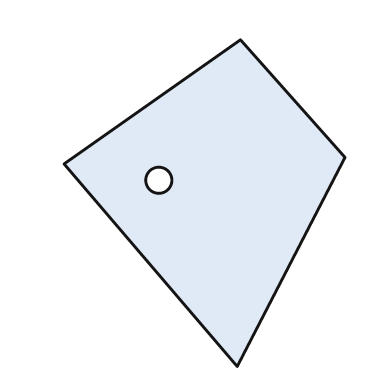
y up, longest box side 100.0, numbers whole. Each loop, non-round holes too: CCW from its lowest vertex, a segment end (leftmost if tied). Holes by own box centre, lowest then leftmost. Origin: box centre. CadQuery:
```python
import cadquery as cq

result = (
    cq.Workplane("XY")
    .moveTo(10.0, -50.0)
    .lineTo(43.0, 14.0)
    .lineTo(11.0, 50.0)
    .lineTo(-43.0, 12.0)
    .close()
    .moveTo(-14.0, 7.0)
    .circle(4.0)
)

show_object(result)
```